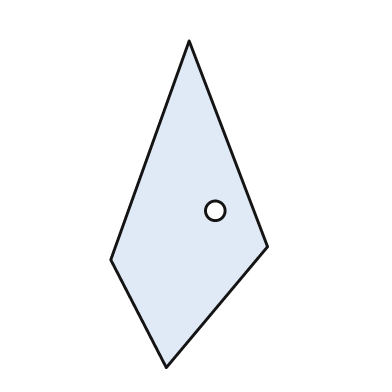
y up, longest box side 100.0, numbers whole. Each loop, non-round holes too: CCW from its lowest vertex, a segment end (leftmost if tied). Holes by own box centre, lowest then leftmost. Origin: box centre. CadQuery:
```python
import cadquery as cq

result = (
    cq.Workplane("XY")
    .moveTo(-7.0, -50.0)
    .lineTo(24.0, -13.0)
    .lineTo(0.0, 50.0)
    .lineTo(-24.0, -17.0)
    .close()
    .moveTo(8.0, -2.0)
    .circle(3.0)
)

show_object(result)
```